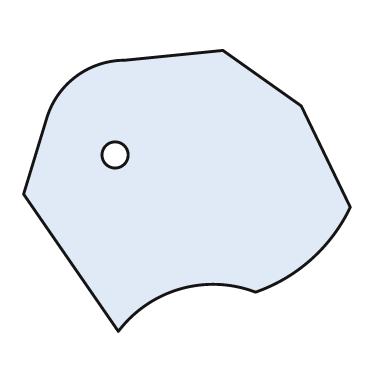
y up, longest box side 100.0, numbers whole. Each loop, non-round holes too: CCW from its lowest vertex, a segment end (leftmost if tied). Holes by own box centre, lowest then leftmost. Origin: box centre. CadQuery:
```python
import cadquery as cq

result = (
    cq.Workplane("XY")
    .moveTo(-21.0, -43.0)
    .threePointArc((-2.0, -30.0), (21.0, -31.0))
    .threePointArc((38.0, -21.0), (50.0, -5.0))
    .lineTo(35.0, 26.0)
    .lineTo(11.0, 43.0)
    .lineTo(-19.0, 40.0)
    .threePointArc((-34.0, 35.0), (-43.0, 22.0))
    .lineTo(-50.0, -1.0)
    .close()
    .moveTo(-22.0, 11.0)
    .circle(4.0)
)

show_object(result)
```